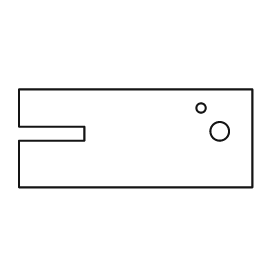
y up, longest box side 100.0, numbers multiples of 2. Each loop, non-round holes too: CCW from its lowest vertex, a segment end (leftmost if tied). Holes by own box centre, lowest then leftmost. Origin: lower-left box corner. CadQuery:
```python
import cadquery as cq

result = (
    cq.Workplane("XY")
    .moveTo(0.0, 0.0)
    .lineTo(100.0, 0.0)
    .lineTo(100.0, 42.0)
    .lineTo(0.0, 42.0)
    .lineTo(0.0, 26.0)
    .lineTo(28.0, 26.0)
    .lineTo(28.0, 20.0)
    .lineTo(0.0, 20.0)
    .close()
    .moveTo(86.0, 24.0)
    .circle(4.0)
    .moveTo(78.0, 34.0)
    .circle(2.0)
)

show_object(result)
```